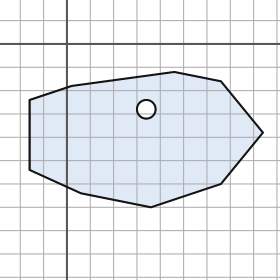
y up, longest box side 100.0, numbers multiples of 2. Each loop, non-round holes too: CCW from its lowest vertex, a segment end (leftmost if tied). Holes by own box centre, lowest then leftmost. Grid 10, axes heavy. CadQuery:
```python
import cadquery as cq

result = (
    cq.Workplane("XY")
    .moveTo(36.0, -70.0)
    .lineTo(66.0, -60.0)
    .lineTo(84.0, -38.0)
    .lineTo(66.0, -16.0)
    .lineTo(46.0, -12.0)
    .lineTo(2.0, -18.0)
    .lineTo(-16.0, -24.0)
    .lineTo(-16.0, -54.0)
    .lineTo(6.0, -64.0)
    .close()
    .moveTo(34.0, -28.0)
    .circle(4.0)
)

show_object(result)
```